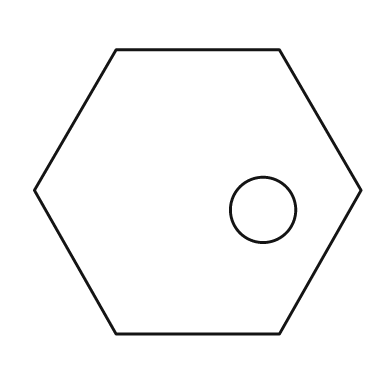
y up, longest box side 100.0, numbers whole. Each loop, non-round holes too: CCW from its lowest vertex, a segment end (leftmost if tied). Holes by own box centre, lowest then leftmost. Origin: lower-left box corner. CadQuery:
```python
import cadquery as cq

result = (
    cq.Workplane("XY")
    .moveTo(25.0, 0.0)
    .lineTo(75.0, 0.0)
    .lineTo(100.0, 44.0)
    .lineTo(75.0, 87.0)
    .lineTo(25.0, 87.0)
    .lineTo(0.0, 44.0)
    .close()
    .moveTo(70.0, 38.0)
    .circle(10.0)
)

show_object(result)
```